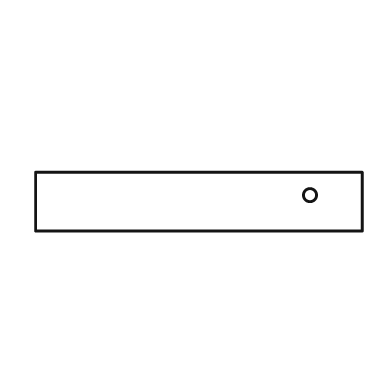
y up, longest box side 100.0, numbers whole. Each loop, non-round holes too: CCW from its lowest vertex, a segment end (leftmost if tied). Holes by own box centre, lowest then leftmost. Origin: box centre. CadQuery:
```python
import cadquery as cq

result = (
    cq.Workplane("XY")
    .moveTo(-50.0, -9.0)
    .lineTo(50.0, -9.0)
    .lineTo(50.0, 9.0)
    .lineTo(-50.0, 9.0)
    .close()
    .moveTo(34.0, 2.0)
    .circle(2.0)
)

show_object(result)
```